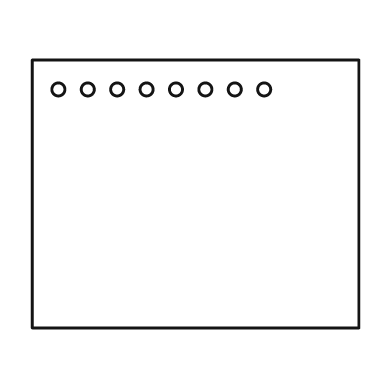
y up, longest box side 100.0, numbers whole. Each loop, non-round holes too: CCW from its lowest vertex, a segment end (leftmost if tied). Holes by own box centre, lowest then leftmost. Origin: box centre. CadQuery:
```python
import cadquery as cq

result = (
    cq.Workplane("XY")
    .moveTo(-50.0, -41.0)
    .lineTo(50.0, -41.0)
    .lineTo(50.0, 41.0)
    .lineTo(-50.0, 41.0)
    .close()
    .moveTo(-42.0, 32.0)
    .circle(2.0)
    .moveTo(-33.0, 32.0)
    .circle(2.0)
    .moveTo(-24.0, 32.0)
    .circle(2.0)
    .moveTo(-15.0, 32.0)
    .circle(2.0)
    .moveTo(-6.0, 32.0)
    .circle(2.0)
    .moveTo(3.0, 32.0)
    .circle(2.0)
    .moveTo(12.0, 32.0)
    .circle(2.0)
    .moveTo(21.0, 32.0)
    .circle(2.0)
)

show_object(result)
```